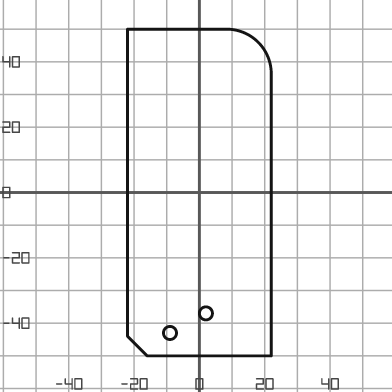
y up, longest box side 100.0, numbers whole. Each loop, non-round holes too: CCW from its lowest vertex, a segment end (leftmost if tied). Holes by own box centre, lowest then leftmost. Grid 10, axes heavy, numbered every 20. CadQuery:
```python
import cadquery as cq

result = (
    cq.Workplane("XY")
    .moveTo(-16.0, -50.0)
    .lineTo(22.0, -50.0)
    .lineTo(22.0, 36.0)
    .threePointArc((18.0, 46.0), (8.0, 50.0))
    .lineTo(-22.0, 50.0)
    .lineTo(-22.0, -44.0)
    .close()
    .moveTo(-9.0, -43.0)
    .circle(2.0)
    .moveTo(2.0, -37.0)
    .circle(2.0)
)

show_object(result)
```